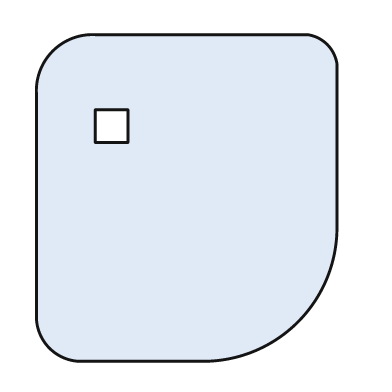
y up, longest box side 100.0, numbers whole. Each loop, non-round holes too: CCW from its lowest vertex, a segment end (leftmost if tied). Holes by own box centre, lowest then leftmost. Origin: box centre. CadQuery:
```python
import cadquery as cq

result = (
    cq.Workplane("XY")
    .moveTo(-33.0, -50.0)
    .lineTo(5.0, -50.0)
    .threePointArc((34.0, -38.0), (46.0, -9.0))
    .lineTo(46.0, 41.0)
    .threePointArc((43.0, 47.0), (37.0, 50.0))
    .lineTo(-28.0, 50.0)
    .threePointArc((-41.0, 45.0), (-46.0, 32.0))
    .lineTo(-46.0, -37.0)
    .threePointArc((-42.0, -46.0), (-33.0, -50.0))
    .close()
    .moveTo(-28.0, 17.0)
    .lineTo(-18.0, 17.0)
    .lineTo(-18.0, 27.0)
    .lineTo(-28.0, 27.0)
    .close()
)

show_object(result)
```